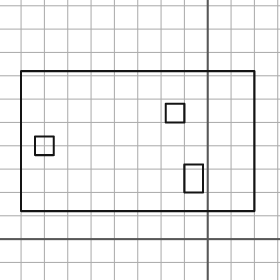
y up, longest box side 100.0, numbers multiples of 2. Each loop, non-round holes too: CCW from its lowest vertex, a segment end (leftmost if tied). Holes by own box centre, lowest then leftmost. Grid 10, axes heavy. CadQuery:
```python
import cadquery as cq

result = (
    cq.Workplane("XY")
    .moveTo(-80.0, 12.0)
    .lineTo(20.0, 12.0)
    .lineTo(20.0, 72.0)
    .lineTo(-80.0, 72.0)
    .close()
    .moveTo(-10.0, 20.0)
    .lineTo(-2.0, 20.0)
    .lineTo(-2.0, 32.0)
    .lineTo(-10.0, 32.0)
    .close()
    .moveTo(-74.0, 36.0)
    .lineTo(-66.0, 36.0)
    .lineTo(-66.0, 44.0)
    .lineTo(-74.0, 44.0)
    .close()
    .moveTo(-18.0, 50.0)
    .lineTo(-10.0, 50.0)
    .lineTo(-10.0, 58.0)
    .lineTo(-18.0, 58.0)
    .close()
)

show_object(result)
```